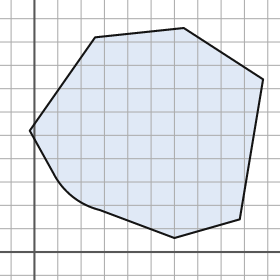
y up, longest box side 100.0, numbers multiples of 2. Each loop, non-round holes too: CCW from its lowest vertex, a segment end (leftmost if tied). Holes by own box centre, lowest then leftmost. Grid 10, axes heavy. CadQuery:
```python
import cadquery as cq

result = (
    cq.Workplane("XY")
    .moveTo(60.0, 6.0)
    .lineTo(88.0, 14.0)
    .lineTo(98.0, 74.0)
    .lineTo(64.0, 96.0)
    .lineTo(26.0, 92.0)
    .lineTo(-2.0, 52.0)
    .lineTo(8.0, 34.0)
    .threePointArc((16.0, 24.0), (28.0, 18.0))
    .close()
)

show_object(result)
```